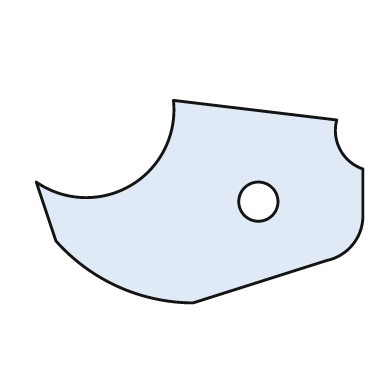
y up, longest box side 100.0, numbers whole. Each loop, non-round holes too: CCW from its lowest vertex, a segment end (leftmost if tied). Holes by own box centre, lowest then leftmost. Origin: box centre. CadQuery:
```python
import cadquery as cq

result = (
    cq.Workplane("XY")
    .moveTo(-2.0, -31.0)
    .lineTo(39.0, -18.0)
    .threePointArc((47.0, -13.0), (50.0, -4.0))
    .lineTo(50.0, 10.0)
    .threePointArc((43.0, 16.0), (42.0, 25.0))
    .lineTo(-8.0, 31.0)
    .threePointArc((-21.0, 5.0), (-50.0, 6.0))
    .lineTo(-44.0, -12.0)
    .threePointArc((-25.0, -26.0), (-2.0, -31.0))
    .close()
    .moveTo(18.0, 0.0)
    .circle(6.0)
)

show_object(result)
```